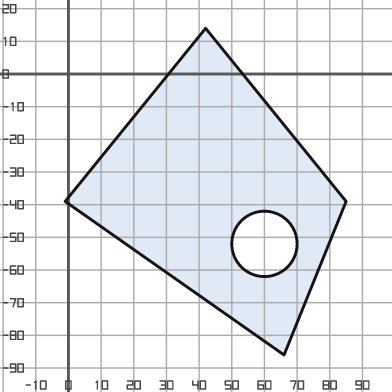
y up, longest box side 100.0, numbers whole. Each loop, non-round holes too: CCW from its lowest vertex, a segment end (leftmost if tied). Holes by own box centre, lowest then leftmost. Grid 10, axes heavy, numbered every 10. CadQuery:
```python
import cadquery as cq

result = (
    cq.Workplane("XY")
    .moveTo(66.0, -86.0)
    .lineTo(85.0, -39.0)
    .lineTo(42.0, 14.0)
    .lineTo(-1.0, -39.0)
    .close()
    .moveTo(60.0, -52.0)
    .circle(10.0)
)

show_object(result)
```